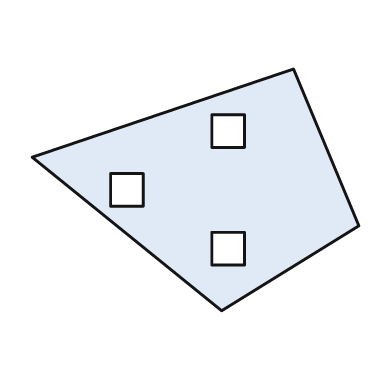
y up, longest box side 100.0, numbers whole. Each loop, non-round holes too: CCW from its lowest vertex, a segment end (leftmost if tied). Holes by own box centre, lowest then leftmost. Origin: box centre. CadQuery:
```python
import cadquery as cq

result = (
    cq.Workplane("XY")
    .moveTo(8.0, -37.0)
    .lineTo(50.0, -11.0)
    .lineTo(30.0, 37.0)
    .lineTo(-50.0, 10.0)
    .close()
    .moveTo(5.0, -23.0)
    .lineTo(15.0, -23.0)
    .lineTo(15.0, -13.0)
    .lineTo(5.0, -13.0)
    .close()
    .moveTo(-26.0, -5.0)
    .lineTo(-16.0, -5.0)
    .lineTo(-16.0, 5.0)
    .lineTo(-26.0, 5.0)
    .close()
    .moveTo(5.0, 13.0)
    .lineTo(15.0, 13.0)
    .lineTo(15.0, 23.0)
    .lineTo(5.0, 23.0)
    .close()
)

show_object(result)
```